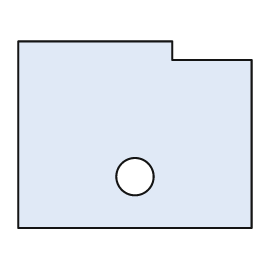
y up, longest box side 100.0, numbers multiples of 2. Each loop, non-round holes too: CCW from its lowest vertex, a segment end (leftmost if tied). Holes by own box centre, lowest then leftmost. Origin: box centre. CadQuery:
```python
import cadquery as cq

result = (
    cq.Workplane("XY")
    .moveTo(-50.0, -40.0)
    .lineTo(50.0, -40.0)
    .lineTo(50.0, 32.0)
    .lineTo(16.0, 32.0)
    .lineTo(16.0, 40.0)
    .lineTo(-50.0, 40.0)
    .close()
    .moveTo(0.0, -18.0)
    .circle(8.0)
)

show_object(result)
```